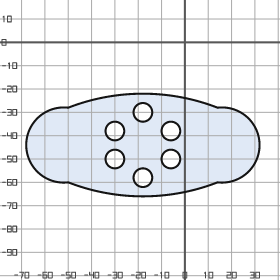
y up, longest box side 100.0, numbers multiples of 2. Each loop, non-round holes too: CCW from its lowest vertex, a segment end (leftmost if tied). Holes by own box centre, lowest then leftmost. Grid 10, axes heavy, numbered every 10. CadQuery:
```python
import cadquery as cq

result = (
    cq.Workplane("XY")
    .moveTo(-50.0, -60.0)
    .threePointArc((-18.0, -66.0), (14.0, -60.0))
    .threePointArc((32.0, -44.0), (14.0, -28.0))
    .threePointArc((-18.0, -22.0), (-50.0, -28.0))
    .threePointArc((-68.0, -44.0), (-50.0, -60.0))
    .close()
    .moveTo(-18.0, -58.0)
    .circle(4.0)
    .moveTo(-30.0, -50.0)
    .circle(4.0)
    .moveTo(-6.0, -50.0)
    .circle(4.0)
    .moveTo(-30.0, -38.0)
    .circle(4.0)
    .moveTo(-6.0, -38.0)
    .circle(4.0)
    .moveTo(-18.0, -30.0)
    .circle(4.0)
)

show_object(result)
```